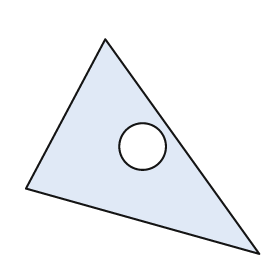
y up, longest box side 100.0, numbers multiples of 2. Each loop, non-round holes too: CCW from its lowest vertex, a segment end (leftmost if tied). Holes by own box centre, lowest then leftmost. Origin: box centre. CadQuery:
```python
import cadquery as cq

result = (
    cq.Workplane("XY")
    .moveTo(50.0, -46.0)
    .lineTo(-16.0, 46.0)
    .lineTo(-50.0, -18.0)
    .close()
    .moveTo(0.0, 0.0)
    .circle(10.0)
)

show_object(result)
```